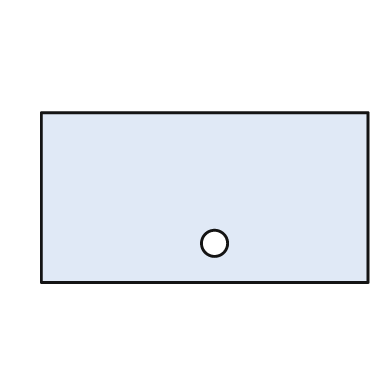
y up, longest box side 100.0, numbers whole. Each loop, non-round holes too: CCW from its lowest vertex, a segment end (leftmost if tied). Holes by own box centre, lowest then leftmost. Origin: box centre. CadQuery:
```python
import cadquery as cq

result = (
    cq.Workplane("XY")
    .moveTo(-50.0, -26.0)
    .lineTo(50.0, -26.0)
    .lineTo(50.0, 26.0)
    .lineTo(-50.0, 26.0)
    .close()
    .moveTo(3.0, -14.0)
    .circle(4.0)
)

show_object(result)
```